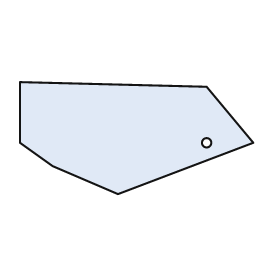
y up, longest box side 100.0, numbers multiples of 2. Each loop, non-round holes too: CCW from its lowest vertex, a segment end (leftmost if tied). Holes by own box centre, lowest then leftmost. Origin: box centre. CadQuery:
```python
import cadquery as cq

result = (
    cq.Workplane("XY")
    .moveTo(-8.0, -24.0)
    .lineTo(50.0, -2.0)
    .lineTo(30.0, 22.0)
    .lineTo(-50.0, 24.0)
    .lineTo(-50.0, -2.0)
    .lineTo(-36.0, -12.0)
    .close()
    .moveTo(30.0, -2.0)
    .circle(2.0)
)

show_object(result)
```